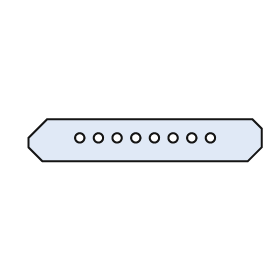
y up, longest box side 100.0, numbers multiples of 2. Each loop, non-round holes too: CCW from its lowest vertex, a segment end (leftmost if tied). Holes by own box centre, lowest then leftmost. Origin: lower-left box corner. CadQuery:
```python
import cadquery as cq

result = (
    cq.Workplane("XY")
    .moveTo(6.0, 0.0)
    .lineTo(94.0, 0.0)
    .lineTo(100.0, 6.0)
    .lineTo(100.0, 14.0)
    .lineTo(96.0, 18.0)
    .lineTo(8.0, 18.0)
    .lineTo(0.0, 10.0)
    .lineTo(0.0, 6.0)
    .close()
    .moveTo(22.0, 10.0)
    .circle(2.0)
    .moveTo(30.0, 10.0)
    .circle(2.0)
    .moveTo(38.0, 10.0)
    .circle(2.0)
    .moveTo(46.0, 10.0)
    .circle(2.0)
    .moveTo(54.0, 10.0)
    .circle(2.0)
    .moveTo(62.0, 10.0)
    .circle(2.0)
    .moveTo(70.0, 10.0)
    .circle(2.0)
    .moveTo(78.0, 10.0)
    .circle(2.0)
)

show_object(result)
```